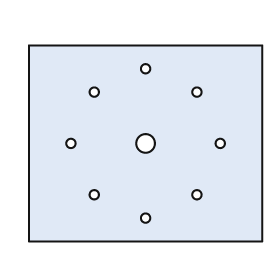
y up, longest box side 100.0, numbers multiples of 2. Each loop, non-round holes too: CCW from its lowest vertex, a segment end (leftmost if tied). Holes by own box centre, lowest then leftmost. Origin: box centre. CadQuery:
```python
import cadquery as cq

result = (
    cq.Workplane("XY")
    .moveTo(-50.0, -42.0)
    .lineTo(50.0, -42.0)
    .lineTo(50.0, 42.0)
    .lineTo(-50.0, 42.0)
    .close()
    .moveTo(0.0, -32.0)
    .circle(2.0)
    .moveTo(-22.0, -22.0)
    .circle(2.0)
    .moveTo(22.0, -22.0)
    .circle(2.0)
    .moveTo(-32.0, 0.0)
    .circle(2.0)
    .moveTo(0.0, 0.0)
    .circle(4.0)
    .moveTo(32.0, 0.0)
    .circle(2.0)
    .moveTo(-22.0, 22.0)
    .circle(2.0)
    .moveTo(22.0, 22.0)
    .circle(2.0)
    .moveTo(0.0, 32.0)
    .circle(2.0)
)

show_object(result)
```